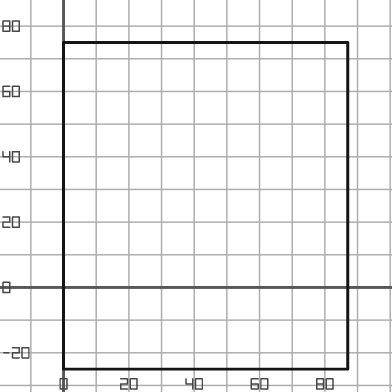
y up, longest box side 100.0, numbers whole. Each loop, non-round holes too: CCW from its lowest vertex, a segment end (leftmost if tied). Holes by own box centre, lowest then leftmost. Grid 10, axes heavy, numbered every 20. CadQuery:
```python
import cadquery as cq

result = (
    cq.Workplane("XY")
    .moveTo(0.0, -25.0)
    .lineTo(87.0, -25.0)
    .lineTo(87.0, 75.0)
    .lineTo(0.0, 75.0)
    .close()
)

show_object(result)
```